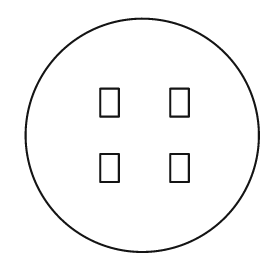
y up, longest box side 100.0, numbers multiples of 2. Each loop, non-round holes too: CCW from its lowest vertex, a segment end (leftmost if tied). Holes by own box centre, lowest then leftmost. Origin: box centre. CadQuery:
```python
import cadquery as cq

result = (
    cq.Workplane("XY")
    .moveTo(0.0, 0.0)
    .circle(50.0)
    .moveTo(-18.0, -20.0)
    .lineTo(-10.0, -20.0)
    .lineTo(-10.0, -8.0)
    .lineTo(-18.0, -8.0)
    .close()
    .moveTo(12.0, -20.0)
    .lineTo(20.0, -20.0)
    .lineTo(20.0, -8.0)
    .lineTo(12.0, -8.0)
    .close()
    .moveTo(-18.0, 8.0)
    .lineTo(-10.0, 8.0)
    .lineTo(-10.0, 20.0)
    .lineTo(-18.0, 20.0)
    .close()
    .moveTo(12.0, 8.0)
    .lineTo(20.0, 8.0)
    .lineTo(20.0, 20.0)
    .lineTo(12.0, 20.0)
    .close()
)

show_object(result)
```